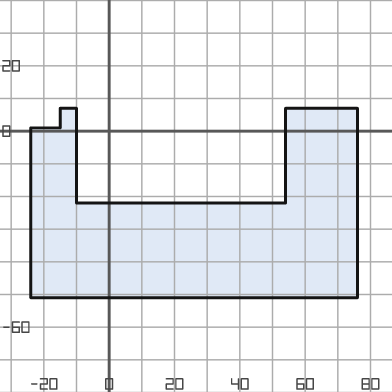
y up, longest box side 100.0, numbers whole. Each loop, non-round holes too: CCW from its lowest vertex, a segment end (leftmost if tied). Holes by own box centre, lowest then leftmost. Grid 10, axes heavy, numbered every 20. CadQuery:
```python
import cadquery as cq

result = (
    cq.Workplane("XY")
    .moveTo(-24.0, -51.0)
    .lineTo(76.0, -51.0)
    .lineTo(76.0, 7.0)
    .lineTo(54.0, 7.0)
    .lineTo(54.0, -22.0)
    .lineTo(-10.0, -22.0)
    .lineTo(-10.0, 7.0)
    .lineTo(-15.0, 7.0)
    .lineTo(-15.0, 1.0)
    .lineTo(-24.0, 1.0)
    .close()
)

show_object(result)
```